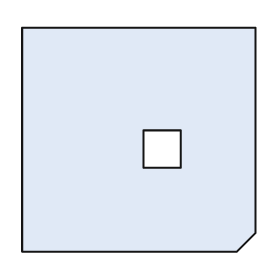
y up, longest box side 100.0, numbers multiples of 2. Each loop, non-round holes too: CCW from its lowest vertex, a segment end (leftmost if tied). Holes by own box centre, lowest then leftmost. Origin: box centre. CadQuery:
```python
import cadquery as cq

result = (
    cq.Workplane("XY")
    .moveTo(-50.0, -48.0)
    .lineTo(42.0, -48.0)
    .lineTo(50.0, -40.0)
    .lineTo(50.0, 48.0)
    .lineTo(-50.0, 48.0)
    .close()
    .moveTo(2.0, -12.0)
    .lineTo(18.0, -12.0)
    .lineTo(18.0, 4.0)
    .lineTo(2.0, 4.0)
    .close()
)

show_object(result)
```